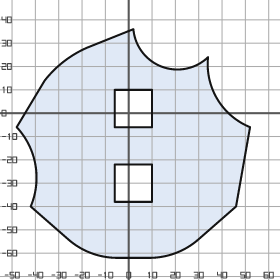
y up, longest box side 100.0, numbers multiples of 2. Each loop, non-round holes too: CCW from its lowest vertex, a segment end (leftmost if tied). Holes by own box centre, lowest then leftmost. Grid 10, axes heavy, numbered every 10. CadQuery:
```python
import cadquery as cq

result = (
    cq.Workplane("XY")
    .moveTo(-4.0, -62.0)
    .lineTo(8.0, -62.0)
    .threePointArc((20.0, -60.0), (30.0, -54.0))
    .lineTo(46.0, -40.0)
    .lineTo(52.0, -6.0)
    .threePointArc((38.0, 6.0), (34.0, 24.0))
    .threePointArc((14.0, 20.0), (2.0, 36.0))
    .lineTo(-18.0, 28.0)
    .threePointArc((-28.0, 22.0), (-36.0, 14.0))
    .lineTo(-48.0, -6.0)
    .threePointArc((-40.0, -22.0), (-42.0, -40.0))
    .lineTo(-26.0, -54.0)
    .threePointArc((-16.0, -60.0), (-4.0, -62.0))
    .close()
    .moveTo(-6.0, -38.0)
    .lineTo(10.0, -38.0)
    .lineTo(10.0, -22.0)
    .lineTo(-6.0, -22.0)
    .close()
    .moveTo(-6.0, -6.0)
    .lineTo(10.0, -6.0)
    .lineTo(10.0, 10.0)
    .lineTo(-6.0, 10.0)
    .close()
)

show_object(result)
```